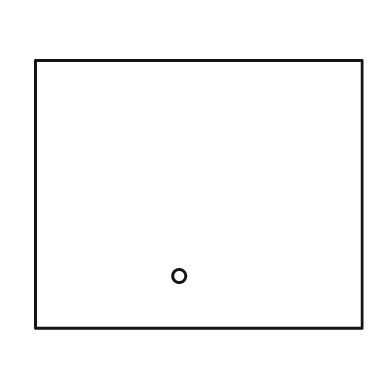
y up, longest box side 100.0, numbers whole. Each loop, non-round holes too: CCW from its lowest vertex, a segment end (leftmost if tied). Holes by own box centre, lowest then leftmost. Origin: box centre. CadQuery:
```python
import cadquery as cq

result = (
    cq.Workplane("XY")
    .moveTo(-50.0, -41.0)
    .lineTo(50.0, -41.0)
    .lineTo(50.0, 41.0)
    .lineTo(-50.0, 41.0)
    .close()
    .moveTo(-6.0, -25.0)
    .circle(2.0)
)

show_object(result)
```